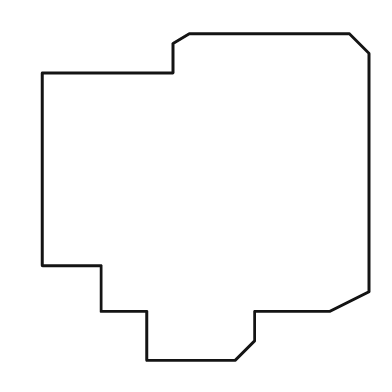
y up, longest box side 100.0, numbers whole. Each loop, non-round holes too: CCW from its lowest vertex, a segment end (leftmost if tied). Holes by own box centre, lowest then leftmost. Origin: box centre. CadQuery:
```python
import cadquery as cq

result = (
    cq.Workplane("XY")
    .moveTo(-18.0, -50.0)
    .lineTo(9.0, -50.0)
    .lineTo(15.0, -44.0)
    .lineTo(15.0, -35.0)
    .lineTo(38.0, -35.0)
    .lineTo(50.0, -29.0)
    .lineTo(50.0, 44.0)
    .lineTo(44.0, 50.0)
    .lineTo(-5.0, 50.0)
    .lineTo(-10.0, 47.0)
    .lineTo(-10.0, 38.0)
    .lineTo(-50.0, 38.0)
    .lineTo(-50.0, -21.0)
    .lineTo(-32.0, -21.0)
    .lineTo(-32.0, -35.0)
    .lineTo(-18.0, -35.0)
    .close()
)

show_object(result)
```